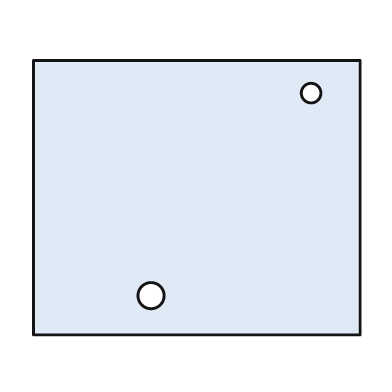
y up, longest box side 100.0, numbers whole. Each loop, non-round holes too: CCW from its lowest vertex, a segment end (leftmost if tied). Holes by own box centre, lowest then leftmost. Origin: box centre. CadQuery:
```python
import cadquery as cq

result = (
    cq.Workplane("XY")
    .moveTo(-50.0, -42.0)
    .lineTo(50.0, -42.0)
    .lineTo(50.0, 42.0)
    .lineTo(-50.0, 42.0)
    .close()
    .moveTo(-14.0, -30.0)
    .circle(4.0)
    .moveTo(35.0, 32.0)
    .circle(3.0)
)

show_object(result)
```